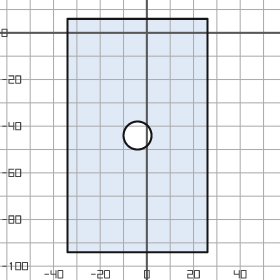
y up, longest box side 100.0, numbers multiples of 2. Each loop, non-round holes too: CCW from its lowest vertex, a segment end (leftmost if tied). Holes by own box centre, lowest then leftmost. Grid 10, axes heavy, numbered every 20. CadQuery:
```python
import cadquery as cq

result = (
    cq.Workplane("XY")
    .moveTo(-34.0, -94.0)
    .lineTo(26.0, -94.0)
    .lineTo(26.0, 6.0)
    .lineTo(-34.0, 6.0)
    .close()
    .moveTo(-4.0, -44.0)
    .circle(6.0)
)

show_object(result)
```